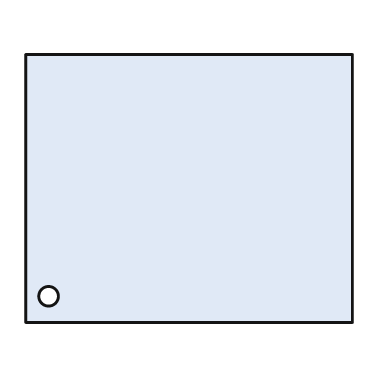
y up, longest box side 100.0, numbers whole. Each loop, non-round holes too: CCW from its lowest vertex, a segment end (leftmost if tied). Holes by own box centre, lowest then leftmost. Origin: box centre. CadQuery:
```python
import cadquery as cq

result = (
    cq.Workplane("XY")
    .moveTo(-50.0, -41.0)
    .lineTo(50.0, -41.0)
    .lineTo(50.0, 41.0)
    .lineTo(-50.0, 41.0)
    .close()
    .moveTo(-43.0, -33.0)
    .circle(3.0)
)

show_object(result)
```